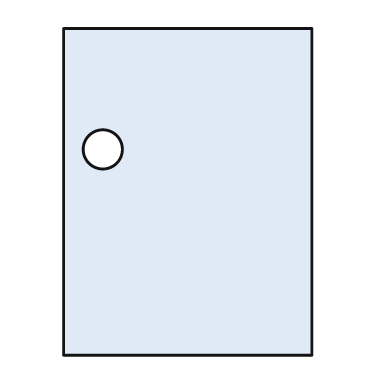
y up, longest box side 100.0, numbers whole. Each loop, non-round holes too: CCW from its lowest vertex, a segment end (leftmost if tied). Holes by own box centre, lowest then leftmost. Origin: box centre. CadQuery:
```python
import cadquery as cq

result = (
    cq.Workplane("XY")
    .moveTo(-38.0, -50.0)
    .lineTo(38.0, -50.0)
    .lineTo(38.0, 50.0)
    .lineTo(-38.0, 50.0)
    .close()
    .moveTo(-26.0, 13.0)
    .circle(6.0)
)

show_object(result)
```